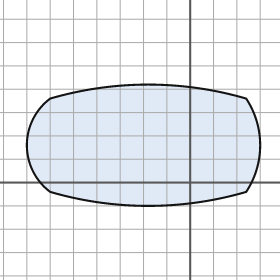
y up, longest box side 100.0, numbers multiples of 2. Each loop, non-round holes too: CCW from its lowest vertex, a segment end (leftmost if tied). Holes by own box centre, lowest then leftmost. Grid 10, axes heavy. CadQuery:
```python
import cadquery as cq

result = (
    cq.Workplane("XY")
    .moveTo(-60.0, -4.0)
    .threePointArc((-18.0, -10.0), (24.0, -4.0))
    .threePointArc((30.0, 16.0), (24.0, 36.0))
    .threePointArc((-18.0, 42.0), (-60.0, 36.0))
    .threePointArc((-70.0, 16.0), (-60.0, -4.0))
    .close()
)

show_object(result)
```